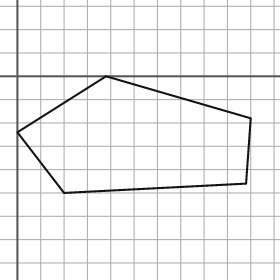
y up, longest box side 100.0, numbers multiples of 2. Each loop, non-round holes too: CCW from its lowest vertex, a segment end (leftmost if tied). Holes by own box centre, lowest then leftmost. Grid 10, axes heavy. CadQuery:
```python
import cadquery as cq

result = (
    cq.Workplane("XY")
    .moveTo(20.0, -50.0)
    .lineTo(98.0, -46.0)
    .lineTo(100.0, -18.0)
    .lineTo(38.0, 0.0)
    .lineTo(0.0, -24.0)
    .close()
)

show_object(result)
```